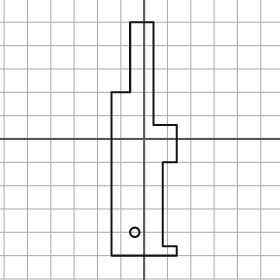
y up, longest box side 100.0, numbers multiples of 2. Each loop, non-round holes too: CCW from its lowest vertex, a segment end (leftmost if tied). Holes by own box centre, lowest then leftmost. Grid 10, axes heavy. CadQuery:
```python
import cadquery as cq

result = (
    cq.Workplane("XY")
    .moveTo(-14.0, -50.0)
    .lineTo(14.0, -50.0)
    .lineTo(14.0, -46.0)
    .lineTo(8.0, -46.0)
    .lineTo(8.0, -10.0)
    .lineTo(14.0, -10.0)
    .lineTo(14.0, 6.0)
    .lineTo(4.0, 6.0)
    .lineTo(4.0, 50.0)
    .lineTo(-6.0, 50.0)
    .lineTo(-6.0, 20.0)
    .lineTo(-14.0, 20.0)
    .close()
    .moveTo(-4.0, -40.0)
    .circle(2.0)
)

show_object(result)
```